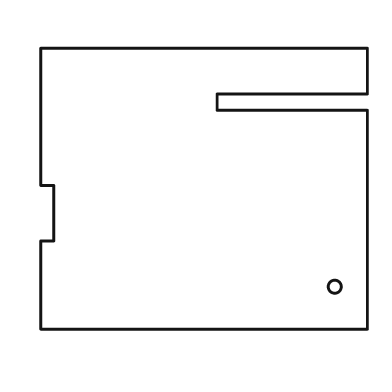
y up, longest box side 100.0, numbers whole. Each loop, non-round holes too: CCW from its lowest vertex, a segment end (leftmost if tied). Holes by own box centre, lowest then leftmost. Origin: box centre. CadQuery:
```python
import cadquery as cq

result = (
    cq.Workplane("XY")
    .moveTo(-50.0, -43.0)
    .lineTo(50.0, -43.0)
    .lineTo(50.0, 24.0)
    .lineTo(4.0, 24.0)
    .lineTo(4.0, 29.0)
    .lineTo(50.0, 29.0)
    .lineTo(50.0, 43.0)
    .lineTo(-50.0, 43.0)
    .lineTo(-50.0, 1.0)
    .lineTo(-46.0, 1.0)
    .lineTo(-46.0, -16.0)
    .lineTo(-50.0, -16.0)
    .close()
    .moveTo(40.0, -30.0)
    .circle(2.0)
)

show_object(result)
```